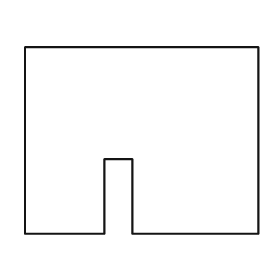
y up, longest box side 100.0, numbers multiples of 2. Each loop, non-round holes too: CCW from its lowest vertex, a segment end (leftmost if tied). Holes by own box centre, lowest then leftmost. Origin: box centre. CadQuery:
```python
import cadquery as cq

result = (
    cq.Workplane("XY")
    .moveTo(-50.0, -40.0)
    .lineTo(-16.0, -40.0)
    .lineTo(-16.0, -8.0)
    .lineTo(-4.0, -8.0)
    .lineTo(-4.0, -40.0)
    .lineTo(50.0, -40.0)
    .lineTo(50.0, 40.0)
    .lineTo(-50.0, 40.0)
    .close()
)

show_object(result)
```